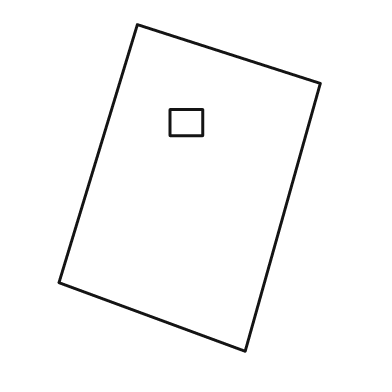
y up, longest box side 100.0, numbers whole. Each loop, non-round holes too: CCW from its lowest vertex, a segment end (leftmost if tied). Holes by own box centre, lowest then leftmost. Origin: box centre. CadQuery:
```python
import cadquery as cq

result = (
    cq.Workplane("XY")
    .moveTo(17.0, -50.0)
    .lineTo(40.0, 32.0)
    .lineTo(-16.0, 50.0)
    .lineTo(-40.0, -29.0)
    .close()
    .moveTo(-6.0, 16.0)
    .lineTo(4.0, 16.0)
    .lineTo(4.0, 24.0)
    .lineTo(-6.0, 24.0)
    .close()
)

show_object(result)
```